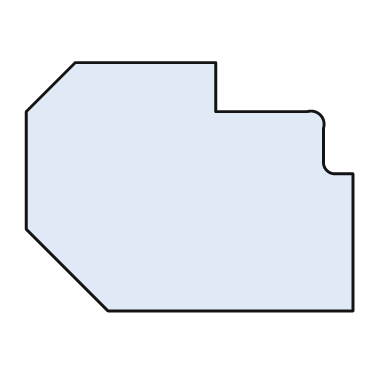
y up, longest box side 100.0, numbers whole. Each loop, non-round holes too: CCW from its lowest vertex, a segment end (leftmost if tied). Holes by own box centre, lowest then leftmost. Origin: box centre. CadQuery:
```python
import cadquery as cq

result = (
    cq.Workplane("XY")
    .moveTo(-25.0, -38.0)
    .lineTo(50.0, -38.0)
    .lineTo(50.0, 4.0)
    .lineTo(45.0, 4.0)
    .threePointArc((42.0, 5.0), (41.0, 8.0))
    .lineTo(41.0, 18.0)
    .threePointArc((40.0, 22.0), (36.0, 23.0))
    .lineTo(8.0, 23.0)
    .lineTo(8.0, 38.0)
    .lineTo(-35.0, 38.0)
    .lineTo(-50.0, 23.0)
    .lineTo(-50.0, -13.0)
    .close()
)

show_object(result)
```